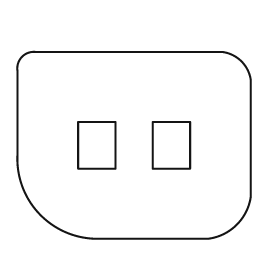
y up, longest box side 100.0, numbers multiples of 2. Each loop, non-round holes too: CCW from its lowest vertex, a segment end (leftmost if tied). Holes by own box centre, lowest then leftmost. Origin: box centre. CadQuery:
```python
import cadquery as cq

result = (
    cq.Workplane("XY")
    .moveTo(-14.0, -40.0)
    .lineTo(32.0, -40.0)
    .threePointArc((44.0, -34.0), (50.0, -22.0))
    .lineTo(50.0, 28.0)
    .threePointArc((46.0, 36.0), (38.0, 40.0))
    .lineTo(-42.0, 40.0)
    .threePointArc((-48.0, 38.0), (-50.0, 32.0))
    .lineTo(-50.0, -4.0)
    .threePointArc((-40.0, -30.0), (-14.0, -40.0))
    .close()
    .moveTo(-24.0, -10.0)
    .lineTo(-8.0, -10.0)
    .lineTo(-8.0, 10.0)
    .lineTo(-24.0, 10.0)
    .close()
    .moveTo(8.0, -10.0)
    .lineTo(24.0, -10.0)
    .lineTo(24.0, 10.0)
    .lineTo(8.0, 10.0)
    .close()
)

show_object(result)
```